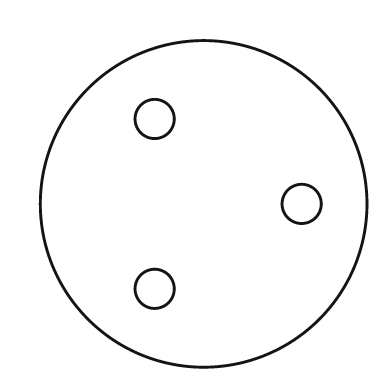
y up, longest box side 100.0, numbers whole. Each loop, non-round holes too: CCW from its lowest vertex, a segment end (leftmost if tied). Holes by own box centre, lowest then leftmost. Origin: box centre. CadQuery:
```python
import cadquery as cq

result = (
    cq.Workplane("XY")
    .moveTo(0.0, 0.0)
    .circle(50.0)
    .moveTo(-15.0, -26.0)
    .circle(6.0)
    .moveTo(30.0, 0.0)
    .circle(6.0)
    .moveTo(-15.0, 26.0)
    .circle(6.0)
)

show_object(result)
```